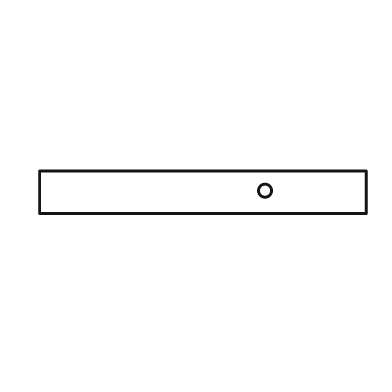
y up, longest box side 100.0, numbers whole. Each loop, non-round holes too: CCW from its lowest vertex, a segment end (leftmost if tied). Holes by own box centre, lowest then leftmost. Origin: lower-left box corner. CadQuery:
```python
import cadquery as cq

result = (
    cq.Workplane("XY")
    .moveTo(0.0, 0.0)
    .lineTo(100.0, 0.0)
    .lineTo(100.0, 13.0)
    .lineTo(0.0, 13.0)
    .close()
    .moveTo(69.0, 7.0)
    .circle(2.0)
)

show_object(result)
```